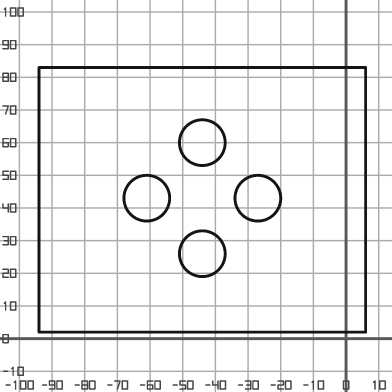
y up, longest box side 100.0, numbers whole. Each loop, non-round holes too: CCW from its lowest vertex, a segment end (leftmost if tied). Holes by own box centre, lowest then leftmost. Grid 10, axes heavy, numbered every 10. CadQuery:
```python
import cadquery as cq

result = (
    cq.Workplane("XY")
    .moveTo(-94.0, 2.0)
    .lineTo(6.0, 2.0)
    .lineTo(6.0, 83.0)
    .lineTo(-94.0, 83.0)
    .close()
    .moveTo(-44.0, 26.0)
    .circle(7.0)
    .moveTo(-61.0, 43.0)
    .circle(7.0)
    .moveTo(-27.0, 43.0)
    .circle(7.0)
    .moveTo(-44.0, 60.0)
    .circle(7.0)
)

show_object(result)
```